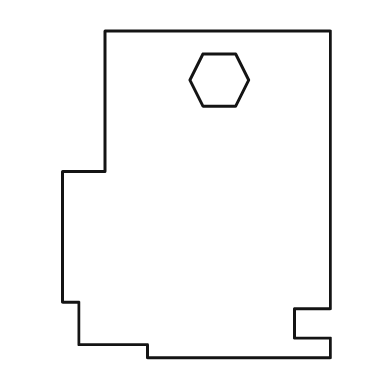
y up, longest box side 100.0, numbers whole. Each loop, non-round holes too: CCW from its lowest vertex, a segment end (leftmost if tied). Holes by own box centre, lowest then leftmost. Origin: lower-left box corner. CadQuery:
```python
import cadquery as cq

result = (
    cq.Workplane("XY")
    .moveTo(26.0, 0.0)
    .lineTo(82.0, 0.0)
    .lineTo(82.0, 6.0)
    .lineTo(71.0, 6.0)
    .lineTo(71.0, 15.0)
    .lineTo(82.0, 15.0)
    .lineTo(82.0, 100.0)
    .lineTo(13.0, 100.0)
    .lineTo(13.0, 57.0)
    .lineTo(0.0, 57.0)
    .lineTo(0.0, 17.0)
    .lineTo(5.0, 17.0)
    .lineTo(5.0, 4.0)
    .lineTo(26.0, 4.0)
    .close()
    .moveTo(43.0, 77.0)
    .lineTo(53.0, 77.0)
    .lineTo(57.0, 85.0)
    .lineTo(53.0, 93.0)
    .lineTo(43.0, 93.0)
    .lineTo(39.0, 85.0)
    .close()
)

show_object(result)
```